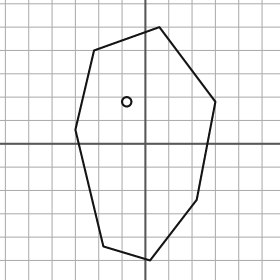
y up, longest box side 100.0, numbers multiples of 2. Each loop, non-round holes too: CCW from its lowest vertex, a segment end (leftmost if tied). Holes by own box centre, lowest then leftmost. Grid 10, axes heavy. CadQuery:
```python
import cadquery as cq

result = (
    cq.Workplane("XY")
    .moveTo(2.0, -50.0)
    .lineTo(22.0, -24.0)
    .lineTo(30.0, 18.0)
    .lineTo(6.0, 50.0)
    .lineTo(-22.0, 40.0)
    .lineTo(-30.0, 6.0)
    .lineTo(-18.0, -44.0)
    .close()
    .moveTo(-8.0, 18.0)
    .circle(2.0)
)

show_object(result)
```